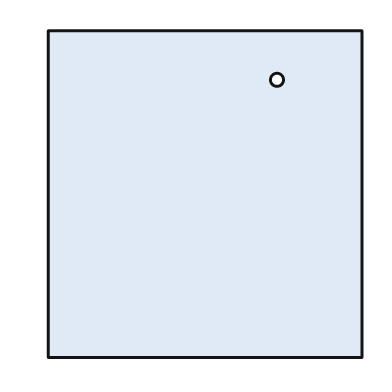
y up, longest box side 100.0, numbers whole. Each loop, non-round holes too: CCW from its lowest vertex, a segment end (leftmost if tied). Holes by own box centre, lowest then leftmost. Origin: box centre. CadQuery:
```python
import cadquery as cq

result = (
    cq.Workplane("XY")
    .moveTo(-48.0, -50.0)
    .lineTo(48.0, -50.0)
    .lineTo(48.0, 50.0)
    .lineTo(-48.0, 50.0)
    .close()
    .moveTo(22.0, 35.0)
    .circle(2.0)
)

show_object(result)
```